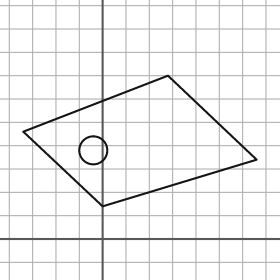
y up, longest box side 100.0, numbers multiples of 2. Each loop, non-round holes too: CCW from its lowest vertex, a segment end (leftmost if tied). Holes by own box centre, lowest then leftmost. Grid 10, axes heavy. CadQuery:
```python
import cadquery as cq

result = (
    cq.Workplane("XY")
    .moveTo(0.0, 14.0)
    .lineTo(66.0, 34.0)
    .lineTo(28.0, 70.0)
    .lineTo(-34.0, 46.0)
    .close()
    .moveTo(-4.0, 38.0)
    .circle(6.0)
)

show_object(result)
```